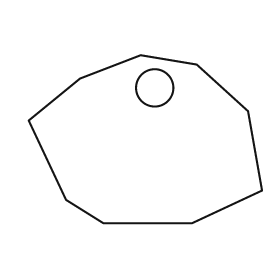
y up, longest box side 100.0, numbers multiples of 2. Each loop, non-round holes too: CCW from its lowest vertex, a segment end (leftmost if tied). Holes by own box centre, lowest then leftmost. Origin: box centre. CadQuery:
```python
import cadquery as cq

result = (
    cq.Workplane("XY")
    .moveTo(-18.0, -36.0)
    .lineTo(20.0, -36.0)
    .lineTo(50.0, -22.0)
    .lineTo(44.0, 12.0)
    .lineTo(22.0, 32.0)
    .lineTo(-2.0, 36.0)
    .lineTo(-28.0, 26.0)
    .lineTo(-50.0, 8.0)
    .lineTo(-34.0, -26.0)
    .close()
    .moveTo(4.0, 22.0)
    .circle(8.0)
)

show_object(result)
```